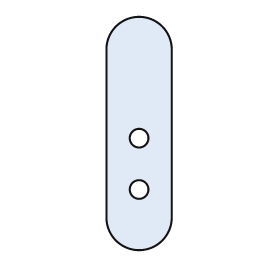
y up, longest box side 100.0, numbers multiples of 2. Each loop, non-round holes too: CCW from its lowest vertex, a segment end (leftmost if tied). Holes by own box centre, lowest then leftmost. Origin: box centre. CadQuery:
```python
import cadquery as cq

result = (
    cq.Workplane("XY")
    .moveTo(-14.0, -36.0)
    .threePointArc((0.0, -50.0), (14.0, -36.0))
    .lineTo(14.0, 36.0)
    .threePointArc((0.0, 50.0), (-14.0, 36.0))
    .close()
    .moveTo(0.0, -24.0)
    .circle(4.0)
    .moveTo(0.0, -2.0)
    .circle(4.0)
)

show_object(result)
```